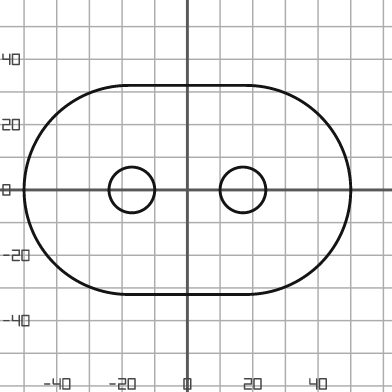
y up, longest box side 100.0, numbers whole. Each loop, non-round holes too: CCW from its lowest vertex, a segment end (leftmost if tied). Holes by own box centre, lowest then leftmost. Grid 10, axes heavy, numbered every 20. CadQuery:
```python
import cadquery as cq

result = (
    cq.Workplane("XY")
    .moveTo(-18.0, -32.0)
    .lineTo(18.0, -32.0)
    .threePointArc((50.0, 0.0), (18.0, 32.0))
    .lineTo(-18.0, 32.0)
    .threePointArc((-50.0, 0.0), (-18.0, -32.0))
    .close()
    .moveTo(-17.0, 0.0)
    .circle(7.0)
    .moveTo(17.0, 0.0)
    .circle(7.0)
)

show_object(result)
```